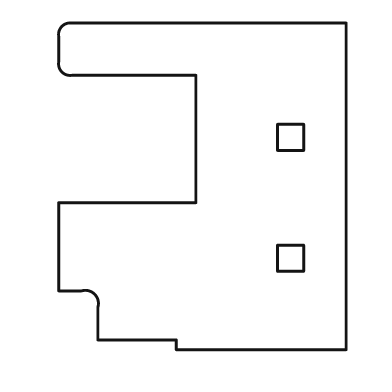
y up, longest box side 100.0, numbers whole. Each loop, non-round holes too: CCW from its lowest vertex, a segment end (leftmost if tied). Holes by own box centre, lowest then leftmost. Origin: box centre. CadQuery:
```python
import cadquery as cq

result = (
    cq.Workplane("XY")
    .moveTo(-8.0, -50.0)
    .lineTo(44.0, -50.0)
    .lineTo(44.0, 50.0)
    .lineTo(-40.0, 50.0)
    .threePointArc((-43.0, 49.0), (-44.0, 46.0))
    .lineTo(-44.0, 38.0)
    .threePointArc((-43.0, 35.0), (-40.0, 34.0))
    .lineTo(-2.0, 34.0)
    .lineTo(-2.0, -5.0)
    .lineTo(-44.0, -5.0)
    .lineTo(-44.0, -32.0)
    .lineTo(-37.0, -32.0)
    .threePointArc((-33.0, -33.0), (-32.0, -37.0))
    .lineTo(-32.0, -47.0)
    .lineTo(-8.0, -47.0)
    .close()
    .moveTo(23.0, -26.0)
    .lineTo(31.0, -26.0)
    .lineTo(31.0, -18.0)
    .lineTo(23.0, -18.0)
    .close()
    .moveTo(23.0, 11.0)
    .lineTo(31.0, 11.0)
    .lineTo(31.0, 19.0)
    .lineTo(23.0, 19.0)
    .close()
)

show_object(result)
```